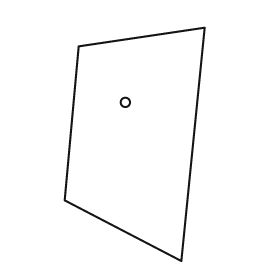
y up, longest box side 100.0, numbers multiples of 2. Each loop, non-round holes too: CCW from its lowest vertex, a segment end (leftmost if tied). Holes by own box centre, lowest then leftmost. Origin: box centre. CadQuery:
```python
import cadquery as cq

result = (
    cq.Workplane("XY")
    .moveTo(20.0, -50.0)
    .lineTo(30.0, 50.0)
    .lineTo(-24.0, 42.0)
    .lineTo(-30.0, -24.0)
    .close()
    .moveTo(-4.0, 18.0)
    .circle(2.0)
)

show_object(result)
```